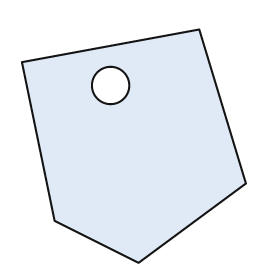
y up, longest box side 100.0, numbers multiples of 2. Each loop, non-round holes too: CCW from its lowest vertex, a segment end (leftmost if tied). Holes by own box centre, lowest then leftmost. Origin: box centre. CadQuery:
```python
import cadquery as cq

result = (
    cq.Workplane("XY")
    .moveTo(2.0, -50.0)
    .lineTo(48.0, -16.0)
    .lineTo(28.0, 50.0)
    .lineTo(-48.0, 36.0)
    .lineTo(-34.0, -32.0)
    .close()
    .moveTo(-10.0, 26.0)
    .circle(8.0)
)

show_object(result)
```